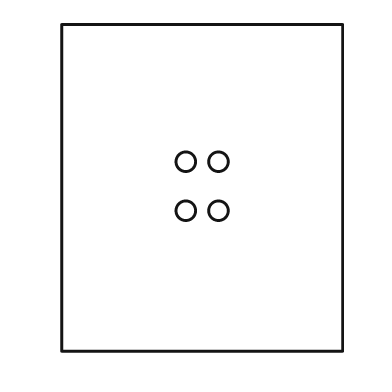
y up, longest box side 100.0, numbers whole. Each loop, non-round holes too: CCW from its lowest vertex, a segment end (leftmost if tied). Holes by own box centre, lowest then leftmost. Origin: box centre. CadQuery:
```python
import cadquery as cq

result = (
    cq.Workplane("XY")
    .moveTo(-43.0, -50.0)
    .lineTo(43.0, -50.0)
    .lineTo(43.0, 50.0)
    .lineTo(-43.0, 50.0)
    .close()
    .moveTo(-5.0, -7.0)
    .circle(3.0)
    .moveTo(5.0, -7.0)
    .circle(3.0)
    .moveTo(-5.0, 8.0)
    .circle(3.0)
    .moveTo(5.0, 8.0)
    .circle(3.0)
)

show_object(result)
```